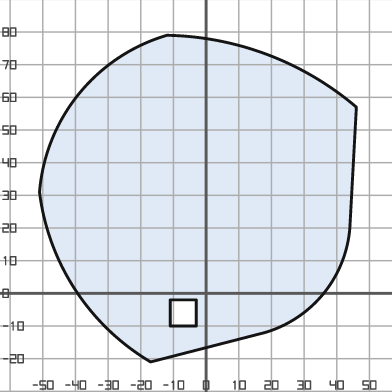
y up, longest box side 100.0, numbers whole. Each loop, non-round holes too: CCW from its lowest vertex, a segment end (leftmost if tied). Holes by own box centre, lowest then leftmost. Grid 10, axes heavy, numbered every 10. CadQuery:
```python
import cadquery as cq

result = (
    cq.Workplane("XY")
    .moveTo(-17.0, -21.0)
    .lineTo(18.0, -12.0)
    .threePointArc((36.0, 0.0), (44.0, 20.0))
    .lineTo(46.0, 57.0)
    .threePointArc((19.0, 73.0), (-12.0, 79.0))
    .threePointArc((-39.0, 61.0), (-51.0, 31.0))
    .threePointArc((-40.0, 1.0), (-17.0, -21.0))
    .close()
    .moveTo(-11.0, -10.0)
    .lineTo(-3.0, -10.0)
    .lineTo(-3.0, -2.0)
    .lineTo(-11.0, -2.0)
    .close()
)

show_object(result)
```